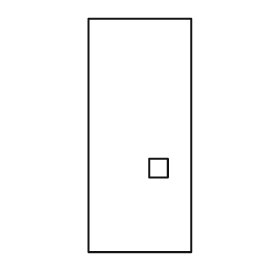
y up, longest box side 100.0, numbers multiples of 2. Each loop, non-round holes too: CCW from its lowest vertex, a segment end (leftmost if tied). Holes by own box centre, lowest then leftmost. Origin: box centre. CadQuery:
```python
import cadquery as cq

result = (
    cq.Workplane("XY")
    .moveTo(-22.0, -50.0)
    .lineTo(22.0, -50.0)
    .lineTo(22.0, 50.0)
    .lineTo(-22.0, 50.0)
    .close()
    .moveTo(4.0, -18.0)
    .lineTo(12.0, -18.0)
    .lineTo(12.0, -10.0)
    .lineTo(4.0, -10.0)
    .close()
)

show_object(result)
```